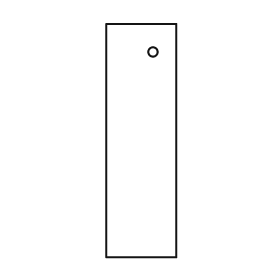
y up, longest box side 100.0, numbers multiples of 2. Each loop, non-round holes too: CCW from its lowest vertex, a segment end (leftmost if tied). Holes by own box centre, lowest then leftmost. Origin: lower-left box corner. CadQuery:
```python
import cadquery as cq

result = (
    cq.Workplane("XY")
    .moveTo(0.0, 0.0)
    .lineTo(30.0, 0.0)
    .lineTo(30.0, 100.0)
    .lineTo(0.0, 100.0)
    .close()
    .moveTo(20.0, 88.0)
    .circle(2.0)
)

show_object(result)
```